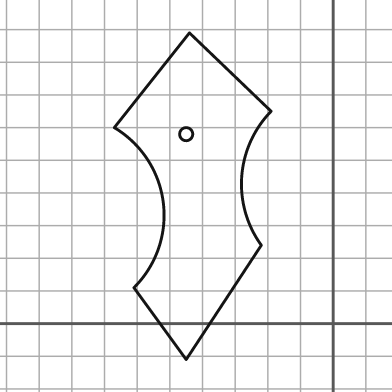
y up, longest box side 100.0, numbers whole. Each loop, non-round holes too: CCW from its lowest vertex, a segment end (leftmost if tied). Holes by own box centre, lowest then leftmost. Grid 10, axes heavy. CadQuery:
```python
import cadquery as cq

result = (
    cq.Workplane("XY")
    .moveTo(-45.0, -11.0)
    .lineTo(-22.0, 24.0)
    .threePointArc((-28.0, 45.0), (-19.0, 65.0))
    .lineTo(-44.0, 89.0)
    .lineTo(-67.0, 60.0)
    .threePointArc((-52.0, 37.0), (-61.0, 11.0))
    .close()
    .moveTo(-45.0, 58.0)
    .circle(2.0)
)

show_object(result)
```